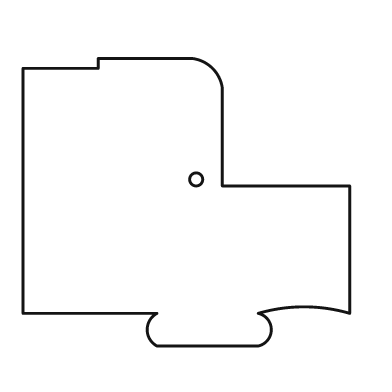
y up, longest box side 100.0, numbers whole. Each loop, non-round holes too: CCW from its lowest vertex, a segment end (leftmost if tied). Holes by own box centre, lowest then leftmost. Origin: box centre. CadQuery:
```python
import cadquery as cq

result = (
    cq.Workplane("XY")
    .moveTo(-9.0, -44.0)
    .lineTo(22.0, -44.0)
    .threePointArc((26.0, -39.0), (22.0, -34.0))
    .threePointArc((36.0, -32.0), (50.0, -34.0))
    .lineTo(50.0, 5.0)
    .lineTo(11.0, 5.0)
    .lineTo(11.0, 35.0)
    .threePointArc((8.0, 41.0), (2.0, 44.0))
    .lineTo(-27.0, 44.0)
    .lineTo(-27.0, 41.0)
    .lineTo(-50.0, 41.0)
    .lineTo(-50.0, -34.0)
    .lineTo(-9.0, -34.0)
    .threePointArc((-12.0, -39.0), (-9.0, -44.0))
    .close()
    .moveTo(3.0, 7.0)
    .circle(2.0)
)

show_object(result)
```